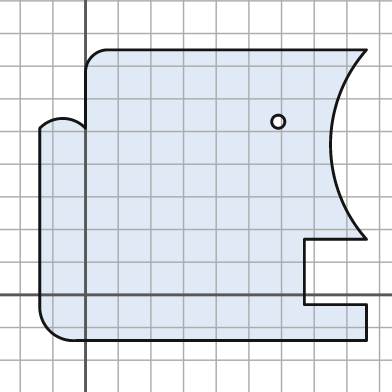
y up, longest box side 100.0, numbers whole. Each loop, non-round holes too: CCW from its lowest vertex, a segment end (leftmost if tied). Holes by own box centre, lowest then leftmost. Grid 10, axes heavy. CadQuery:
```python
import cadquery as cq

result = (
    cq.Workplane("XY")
    .moveTo(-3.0, -14.0)
    .lineTo(86.0, -14.0)
    .lineTo(86.0, -3.0)
    .lineTo(67.0, -3.0)
    .lineTo(67.0, 17.0)
    .lineTo(86.0, 17.0)
    .threePointArc((75.0, 46.0), (86.0, 75.0))
    .lineTo(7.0, 75.0)
    .threePointArc((2.0, 73.0), (0.0, 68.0))
    .lineTo(0.0, 51.0)
    .threePointArc((-7.0, 54.0), (-14.0, 51.0))
    .lineTo(-14.0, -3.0)
    .threePointArc((-11.0, -11.0), (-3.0, -14.0))
    .close()
    .moveTo(59.0, 53.0)
    .circle(2.0)
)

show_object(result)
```